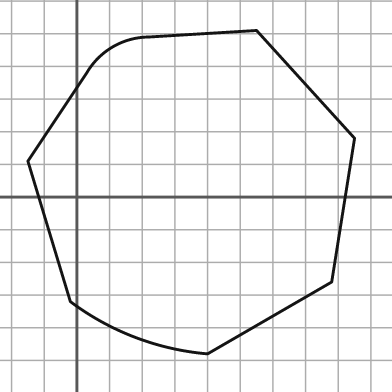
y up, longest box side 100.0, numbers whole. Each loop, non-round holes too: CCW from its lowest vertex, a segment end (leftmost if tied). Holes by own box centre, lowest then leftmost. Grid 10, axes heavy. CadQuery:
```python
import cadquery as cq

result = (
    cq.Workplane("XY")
    .moveTo(40.0, -48.0)
    .lineTo(78.0, -26.0)
    .lineTo(85.0, 18.0)
    .lineTo(55.0, 51.0)
    .lineTo(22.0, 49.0)
    .threePointArc((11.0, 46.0), (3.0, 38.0))
    .lineTo(-15.0, 11.0)
    .lineTo(-2.0, -32.0)
    .threePointArc((18.0, -43.0), (40.0, -48.0))
    .close()
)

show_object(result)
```